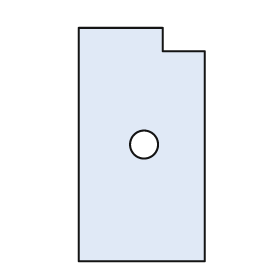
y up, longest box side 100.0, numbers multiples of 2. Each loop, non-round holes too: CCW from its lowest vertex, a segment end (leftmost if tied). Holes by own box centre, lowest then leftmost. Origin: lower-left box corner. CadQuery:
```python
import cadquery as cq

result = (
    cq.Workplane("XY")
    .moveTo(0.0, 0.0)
    .lineTo(54.0, 0.0)
    .lineTo(54.0, 90.0)
    .lineTo(36.0, 90.0)
    .lineTo(36.0, 100.0)
    .lineTo(0.0, 100.0)
    .close()
    .moveTo(28.0, 50.0)
    .circle(6.0)
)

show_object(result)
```